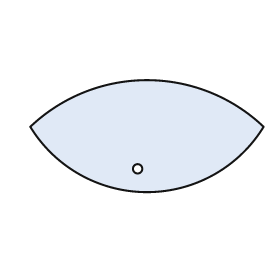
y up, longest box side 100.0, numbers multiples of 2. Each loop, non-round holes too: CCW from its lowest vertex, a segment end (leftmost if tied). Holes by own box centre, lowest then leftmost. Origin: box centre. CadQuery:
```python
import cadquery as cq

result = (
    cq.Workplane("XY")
    .moveTo(-50.0, 4.0)
    .threePointArc((0.0, -24.0), (50.0, 4.0))
    .threePointArc((0.0, 24.0), (-50.0, 4.0))
    .close()
    .moveTo(-4.0, -14.0)
    .circle(2.0)
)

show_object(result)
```